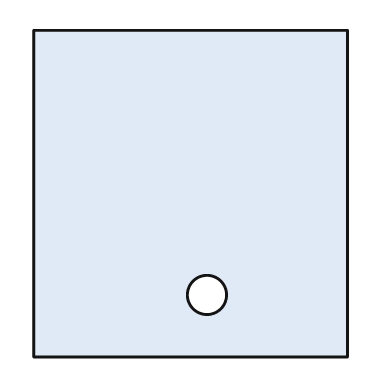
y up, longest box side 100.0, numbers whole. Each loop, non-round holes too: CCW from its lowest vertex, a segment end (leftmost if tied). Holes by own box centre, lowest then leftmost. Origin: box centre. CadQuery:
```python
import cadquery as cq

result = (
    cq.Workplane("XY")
    .moveTo(-48.0, -50.0)
    .lineTo(48.0, -50.0)
    .lineTo(48.0, 50.0)
    .lineTo(-48.0, 50.0)
    .close()
    .moveTo(5.0, -31.0)
    .circle(6.0)
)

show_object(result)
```